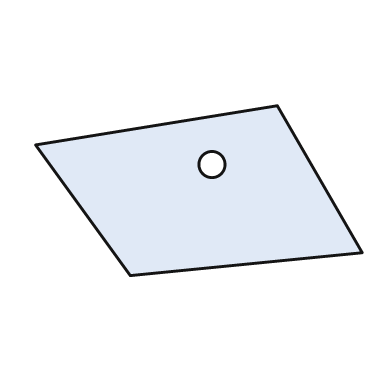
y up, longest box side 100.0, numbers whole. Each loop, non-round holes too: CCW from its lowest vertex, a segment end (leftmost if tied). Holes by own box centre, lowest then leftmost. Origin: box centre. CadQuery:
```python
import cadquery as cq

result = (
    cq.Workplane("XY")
    .moveTo(-21.0, -26.0)
    .lineTo(50.0, -19.0)
    .lineTo(24.0, 26.0)
    .lineTo(-50.0, 14.0)
    .close()
    .moveTo(4.0, 8.0)
    .circle(4.0)
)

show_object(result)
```